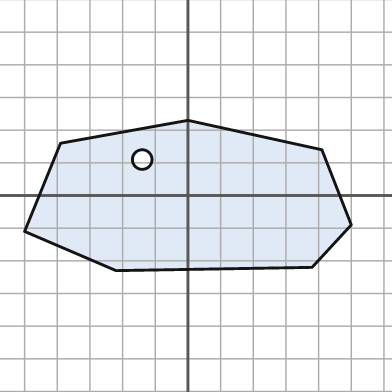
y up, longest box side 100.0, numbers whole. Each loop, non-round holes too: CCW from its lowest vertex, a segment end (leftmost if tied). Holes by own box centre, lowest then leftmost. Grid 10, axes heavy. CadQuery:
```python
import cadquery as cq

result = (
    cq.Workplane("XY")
    .moveTo(-22.0, -23.0)
    .lineTo(38.0, -22.0)
    .lineTo(50.0, -9.0)
    .lineTo(41.0, 14.0)
    .lineTo(0.0, 23.0)
    .lineTo(-39.0, 16.0)
    .lineTo(-50.0, -11.0)
    .close()
    .moveTo(-14.0, 11.0)
    .circle(3.0)
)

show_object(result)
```